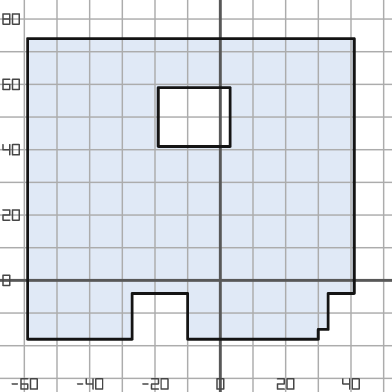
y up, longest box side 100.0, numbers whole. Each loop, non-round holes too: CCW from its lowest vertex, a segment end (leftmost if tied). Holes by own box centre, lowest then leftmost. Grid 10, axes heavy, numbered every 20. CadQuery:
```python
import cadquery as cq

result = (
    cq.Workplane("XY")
    .moveTo(-59.0, -18.0)
    .lineTo(-27.0, -18.0)
    .lineTo(-27.0, -4.0)
    .lineTo(-10.0, -4.0)
    .lineTo(-10.0, -18.0)
    .lineTo(30.0, -18.0)
    .lineTo(30.0, -15.0)
    .lineTo(33.0, -15.0)
    .lineTo(33.0, -4.0)
    .lineTo(41.0, -4.0)
    .lineTo(41.0, 74.0)
    .lineTo(-59.0, 74.0)
    .close()
    .moveTo(-19.0, 41.0)
    .lineTo(3.0, 41.0)
    .lineTo(3.0, 59.0)
    .lineTo(-19.0, 59.0)
    .close()
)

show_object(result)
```